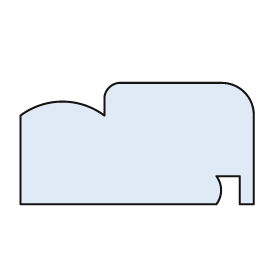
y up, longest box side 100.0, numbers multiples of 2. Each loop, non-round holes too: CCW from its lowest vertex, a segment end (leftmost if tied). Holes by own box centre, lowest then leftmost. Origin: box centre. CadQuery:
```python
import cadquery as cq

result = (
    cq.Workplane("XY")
    .moveTo(-50.0, -26.0)
    .lineTo(34.0, -26.0)
    .threePointArc((36.0, -20.0), (34.0, -14.0))
    .lineTo(44.0, -14.0)
    .lineTo(44.0, -26.0)
    .lineTo(50.0, -26.0)
    .lineTo(50.0, 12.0)
    .threePointArc((46.0, 22.0), (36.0, 26.0))
    .lineTo(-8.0, 26.0)
    .threePointArc((-12.0, 24.0), (-14.0, 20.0))
    .lineTo(-14.0, 12.0)
    .threePointArc((-32.0, 18.0), (-50.0, 12.0))
    .close()
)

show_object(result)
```